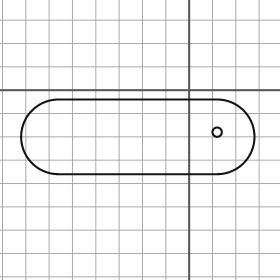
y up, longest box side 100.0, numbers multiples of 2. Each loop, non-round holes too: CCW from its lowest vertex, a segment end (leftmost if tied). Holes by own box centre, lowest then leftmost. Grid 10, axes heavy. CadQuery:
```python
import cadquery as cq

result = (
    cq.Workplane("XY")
    .moveTo(-56.0, -36.0)
    .lineTo(12.0, -36.0)
    .threePointArc((28.0, -20.0), (12.0, -4.0))
    .lineTo(-56.0, -4.0)
    .threePointArc((-72.0, -20.0), (-56.0, -36.0))
    .close()
    .moveTo(12.0, -18.0)
    .circle(2.0)
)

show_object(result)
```